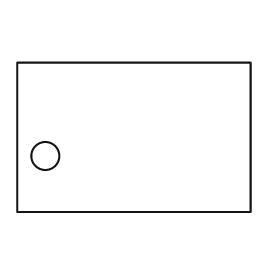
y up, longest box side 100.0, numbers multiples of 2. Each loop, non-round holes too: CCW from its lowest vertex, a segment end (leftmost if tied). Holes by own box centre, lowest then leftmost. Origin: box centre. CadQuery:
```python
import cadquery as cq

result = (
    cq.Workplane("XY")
    .moveTo(-50.0, -32.0)
    .lineTo(50.0, -32.0)
    .lineTo(50.0, 32.0)
    .lineTo(-50.0, 32.0)
    .close()
    .moveTo(-38.0, -8.0)
    .circle(6.0)
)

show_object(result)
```